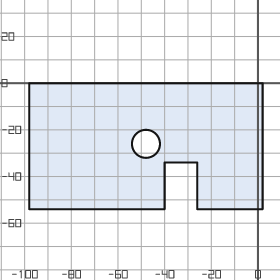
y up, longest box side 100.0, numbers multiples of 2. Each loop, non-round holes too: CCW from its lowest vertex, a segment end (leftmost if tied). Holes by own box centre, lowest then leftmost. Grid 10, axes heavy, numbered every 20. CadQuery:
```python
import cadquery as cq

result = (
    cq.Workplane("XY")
    .moveTo(-98.0, -54.0)
    .lineTo(-40.0, -54.0)
    .lineTo(-40.0, -34.0)
    .lineTo(-26.0, -34.0)
    .lineTo(-26.0, -54.0)
    .lineTo(2.0, -54.0)
    .lineTo(2.0, 0.0)
    .lineTo(-98.0, 0.0)
    .close()
    .moveTo(-48.0, -26.0)
    .circle(6.0)
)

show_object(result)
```